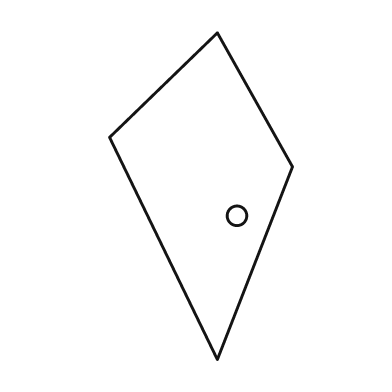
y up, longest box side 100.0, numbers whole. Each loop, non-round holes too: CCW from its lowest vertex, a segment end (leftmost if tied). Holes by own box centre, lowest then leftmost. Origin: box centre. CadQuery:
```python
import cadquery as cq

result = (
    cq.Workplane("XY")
    .moveTo(5.0, -50.0)
    .lineTo(28.0, 9.0)
    .lineTo(5.0, 50.0)
    .lineTo(-28.0, 18.0)
    .close()
    .moveTo(11.0, -6.0)
    .circle(3.0)
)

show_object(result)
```